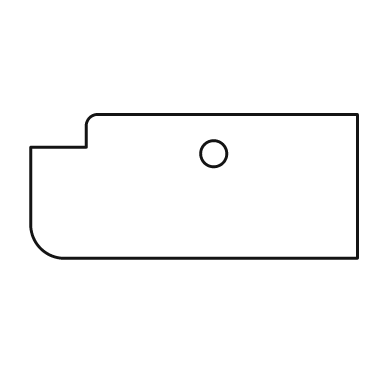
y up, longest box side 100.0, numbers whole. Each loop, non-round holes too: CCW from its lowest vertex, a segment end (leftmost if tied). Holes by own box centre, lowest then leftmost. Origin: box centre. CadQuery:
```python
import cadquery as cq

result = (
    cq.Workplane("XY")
    .moveTo(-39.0, -22.0)
    .lineTo(50.0, -22.0)
    .lineTo(50.0, 22.0)
    .lineTo(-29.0, 22.0)
    .threePointArc((-32.0, 21.0), (-33.0, 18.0))
    .lineTo(-33.0, 12.0)
    .lineTo(-50.0, 12.0)
    .lineTo(-50.0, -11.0)
    .threePointArc((-47.0, -19.0), (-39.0, -22.0))
    .close()
    .moveTo(6.0, 10.0)
    .circle(4.0)
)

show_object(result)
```